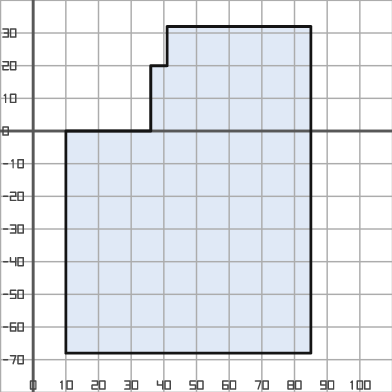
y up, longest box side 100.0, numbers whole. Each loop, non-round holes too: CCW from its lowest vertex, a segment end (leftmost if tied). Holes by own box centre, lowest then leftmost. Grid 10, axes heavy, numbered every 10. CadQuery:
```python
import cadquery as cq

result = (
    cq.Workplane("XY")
    .moveTo(10.0, -68.0)
    .lineTo(85.0, -68.0)
    .lineTo(85.0, 32.0)
    .lineTo(41.0, 32.0)
    .lineTo(41.0, 20.0)
    .lineTo(36.0, 20.0)
    .lineTo(36.0, 0.0)
    .lineTo(10.0, 0.0)
    .close()
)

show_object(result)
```